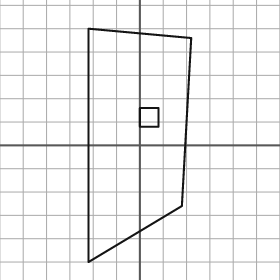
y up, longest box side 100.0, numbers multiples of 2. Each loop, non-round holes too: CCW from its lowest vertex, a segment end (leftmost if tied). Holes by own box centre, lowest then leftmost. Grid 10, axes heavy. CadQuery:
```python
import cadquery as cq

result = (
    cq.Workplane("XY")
    .moveTo(-22.0, -50.0)
    .lineTo(18.0, -26.0)
    .lineTo(22.0, 46.0)
    .lineTo(-22.0, 50.0)
    .close()
    .moveTo(0.0, 8.0)
    .lineTo(8.0, 8.0)
    .lineTo(8.0, 16.0)
    .lineTo(0.0, 16.0)
    .close()
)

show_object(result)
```